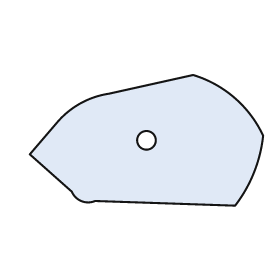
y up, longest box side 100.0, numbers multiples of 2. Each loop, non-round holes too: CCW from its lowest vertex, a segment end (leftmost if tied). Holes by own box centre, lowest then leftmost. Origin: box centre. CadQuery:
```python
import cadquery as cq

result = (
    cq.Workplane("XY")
    .moveTo(38.0, -28.0)
    .threePointArc((46.0, -14.0), (50.0, 2.0))
    .threePointArc((38.0, 18.0), (20.0, 28.0))
    .lineTo(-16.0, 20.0)
    .threePointArc((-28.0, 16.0), (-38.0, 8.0))
    .lineTo(-50.0, -6.0)
    .lineTo(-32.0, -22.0)
    .threePointArc((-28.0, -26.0), (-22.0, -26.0))
    .close()
    .moveTo(0.0, 0.0)
    .circle(4.0)
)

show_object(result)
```